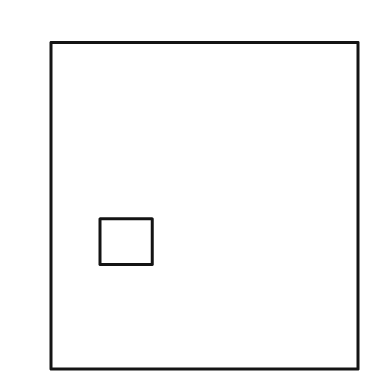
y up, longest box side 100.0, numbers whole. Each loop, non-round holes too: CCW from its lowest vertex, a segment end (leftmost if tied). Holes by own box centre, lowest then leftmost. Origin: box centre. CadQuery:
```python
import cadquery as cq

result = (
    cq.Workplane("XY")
    .moveTo(-47.0, -50.0)
    .lineTo(47.0, -50.0)
    .lineTo(47.0, 50.0)
    .lineTo(-47.0, 50.0)
    .close()
    .moveTo(-32.0, -18.0)
    .lineTo(-16.0, -18.0)
    .lineTo(-16.0, -4.0)
    .lineTo(-32.0, -4.0)
    .close()
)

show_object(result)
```